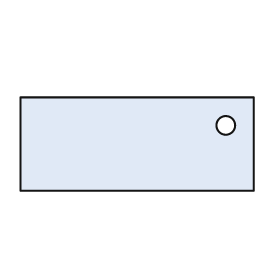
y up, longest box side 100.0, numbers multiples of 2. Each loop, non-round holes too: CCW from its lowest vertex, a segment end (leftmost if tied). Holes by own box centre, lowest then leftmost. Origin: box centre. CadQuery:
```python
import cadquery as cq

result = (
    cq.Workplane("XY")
    .moveTo(-50.0, -20.0)
    .lineTo(50.0, -20.0)
    .lineTo(50.0, 20.0)
    .lineTo(-50.0, 20.0)
    .close()
    .moveTo(38.0, 8.0)
    .circle(4.0)
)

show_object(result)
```